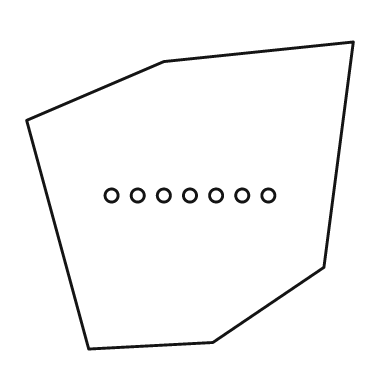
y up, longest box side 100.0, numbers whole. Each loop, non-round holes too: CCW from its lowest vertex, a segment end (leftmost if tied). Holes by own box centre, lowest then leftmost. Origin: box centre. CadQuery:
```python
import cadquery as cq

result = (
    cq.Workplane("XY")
    .moveTo(-31.0, -47.0)
    .lineTo(7.0, -45.0)
    .lineTo(41.0, -22.0)
    .lineTo(50.0, 47.0)
    .lineTo(-8.0, 41.0)
    .lineTo(-50.0, 23.0)
    .close()
    .moveTo(-24.0, 0.0)
    .circle(2.0)
    .moveTo(-16.0, 0.0)
    .circle(2.0)
    .moveTo(-8.0, 0.0)
    .circle(2.0)
    .moveTo(0.0, 0.0)
    .circle(2.0)
    .moveTo(8.0, 0.0)
    .circle(2.0)
    .moveTo(16.0, 0.0)
    .circle(2.0)
    .moveTo(24.0, 0.0)
    .circle(2.0)
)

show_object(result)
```